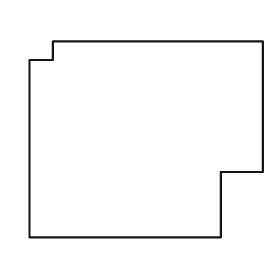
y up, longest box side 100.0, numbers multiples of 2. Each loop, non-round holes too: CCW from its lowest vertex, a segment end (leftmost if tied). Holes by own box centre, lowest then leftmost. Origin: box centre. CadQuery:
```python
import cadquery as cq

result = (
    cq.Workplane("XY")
    .moveTo(-50.0, -42.0)
    .lineTo(32.0, -42.0)
    .lineTo(32.0, -14.0)
    .lineTo(50.0, -14.0)
    .lineTo(50.0, 42.0)
    .lineTo(-40.0, 42.0)
    .lineTo(-40.0, 34.0)
    .lineTo(-50.0, 34.0)
    .close()
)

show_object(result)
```